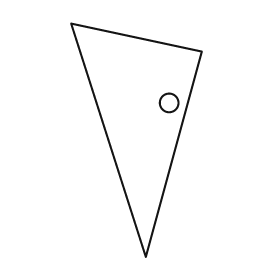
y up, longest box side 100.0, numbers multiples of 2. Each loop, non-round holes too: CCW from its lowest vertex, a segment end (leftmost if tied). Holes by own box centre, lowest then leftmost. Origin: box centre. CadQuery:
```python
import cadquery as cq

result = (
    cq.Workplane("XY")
    .moveTo(4.0, -50.0)
    .lineTo(28.0, 38.0)
    .lineTo(-28.0, 50.0)
    .close()
    .moveTo(14.0, 16.0)
    .circle(4.0)
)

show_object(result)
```